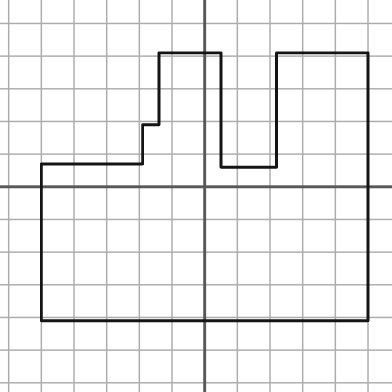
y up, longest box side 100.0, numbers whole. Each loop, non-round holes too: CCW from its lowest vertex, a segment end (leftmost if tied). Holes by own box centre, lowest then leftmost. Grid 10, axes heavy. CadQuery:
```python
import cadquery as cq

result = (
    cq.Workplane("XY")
    .moveTo(-50.0, -41.0)
    .lineTo(50.0, -41.0)
    .lineTo(50.0, 41.0)
    .lineTo(22.0, 41.0)
    .lineTo(22.0, 6.0)
    .lineTo(5.0, 6.0)
    .lineTo(5.0, 41.0)
    .lineTo(-14.0, 41.0)
    .lineTo(-14.0, 19.0)
    .lineTo(-19.0, 19.0)
    .lineTo(-19.0, 7.0)
    .lineTo(-50.0, 7.0)
    .close()
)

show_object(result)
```